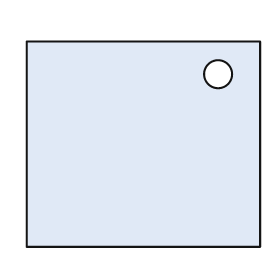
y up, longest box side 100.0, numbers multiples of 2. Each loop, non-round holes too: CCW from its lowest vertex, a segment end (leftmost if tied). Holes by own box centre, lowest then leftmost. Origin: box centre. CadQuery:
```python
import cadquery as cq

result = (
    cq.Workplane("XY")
    .moveTo(-50.0, -44.0)
    .lineTo(50.0, -44.0)
    .lineTo(50.0, 44.0)
    .lineTo(-50.0, 44.0)
    .close()
    .moveTo(32.0, 30.0)
    .circle(6.0)
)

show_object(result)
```